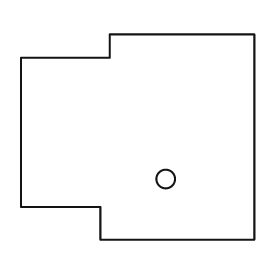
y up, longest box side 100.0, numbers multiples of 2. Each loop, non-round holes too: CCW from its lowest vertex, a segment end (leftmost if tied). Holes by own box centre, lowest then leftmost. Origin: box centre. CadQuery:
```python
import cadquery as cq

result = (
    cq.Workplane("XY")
    .moveTo(-16.0, -44.0)
    .lineTo(50.0, -44.0)
    .lineTo(50.0, 44.0)
    .lineTo(-12.0, 44.0)
    .lineTo(-12.0, 34.0)
    .lineTo(-50.0, 34.0)
    .lineTo(-50.0, -30.0)
    .lineTo(-16.0, -30.0)
    .close()
    .moveTo(12.0, -18.0)
    .circle(4.0)
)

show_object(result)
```